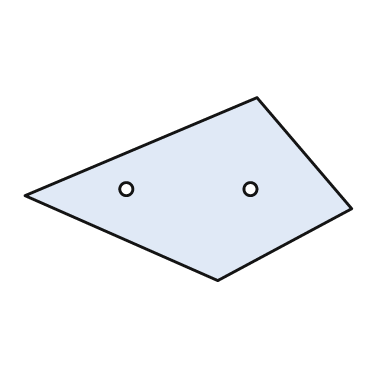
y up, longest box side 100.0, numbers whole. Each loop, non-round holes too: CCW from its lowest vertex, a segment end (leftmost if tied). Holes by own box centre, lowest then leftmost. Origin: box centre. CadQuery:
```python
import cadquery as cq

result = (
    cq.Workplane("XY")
    .moveTo(9.0, -28.0)
    .lineTo(50.0, -6.0)
    .lineTo(21.0, 28.0)
    .lineTo(-50.0, -2.0)
    .close()
    .moveTo(-19.0, 0.0)
    .circle(2.0)
    .moveTo(19.0, 0.0)
    .circle(2.0)
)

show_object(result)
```